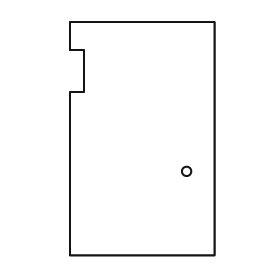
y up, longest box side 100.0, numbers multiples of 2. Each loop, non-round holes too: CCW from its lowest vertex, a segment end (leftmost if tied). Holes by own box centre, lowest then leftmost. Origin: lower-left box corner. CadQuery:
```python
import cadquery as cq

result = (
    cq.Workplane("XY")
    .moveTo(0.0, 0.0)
    .lineTo(62.0, 0.0)
    .lineTo(62.0, 100.0)
    .lineTo(0.0, 100.0)
    .lineTo(0.0, 88.0)
    .lineTo(6.0, 88.0)
    .lineTo(6.0, 70.0)
    .lineTo(0.0, 70.0)
    .close()
    .moveTo(50.0, 36.0)
    .circle(2.0)
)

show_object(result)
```